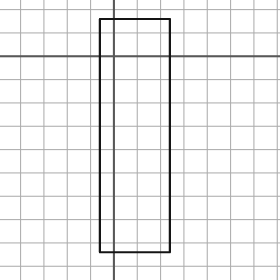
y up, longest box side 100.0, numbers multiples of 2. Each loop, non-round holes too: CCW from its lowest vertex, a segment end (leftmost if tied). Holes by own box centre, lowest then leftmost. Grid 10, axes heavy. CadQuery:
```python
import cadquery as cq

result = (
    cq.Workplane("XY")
    .moveTo(-6.0, -84.0)
    .lineTo(24.0, -84.0)
    .lineTo(24.0, 16.0)
    .lineTo(-6.0, 16.0)
    .close()
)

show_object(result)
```